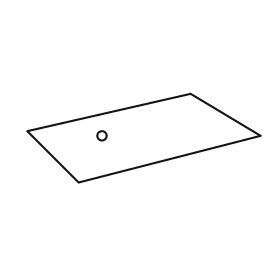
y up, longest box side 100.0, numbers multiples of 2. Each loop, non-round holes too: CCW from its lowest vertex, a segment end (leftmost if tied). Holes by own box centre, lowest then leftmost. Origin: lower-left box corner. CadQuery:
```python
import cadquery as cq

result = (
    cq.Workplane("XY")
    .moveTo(22.0, 0.0)
    .lineTo(100.0, 20.0)
    .lineTo(70.0, 38.0)
    .lineTo(0.0, 22.0)
    .close()
    .moveTo(32.0, 20.0)
    .circle(2.0)
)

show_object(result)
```